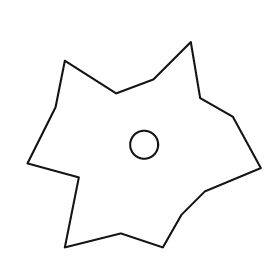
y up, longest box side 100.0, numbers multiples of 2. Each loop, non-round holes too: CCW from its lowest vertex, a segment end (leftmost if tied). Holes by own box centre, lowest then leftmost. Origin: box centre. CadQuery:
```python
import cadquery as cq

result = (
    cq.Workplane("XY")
    .moveTo(-34.0, -44.0)
    .lineTo(-10.0, -38.0)
    .lineTo(8.0, -44.0)
    .lineTo(16.0, -30.0)
    .lineTo(26.0, -20.0)
    .lineTo(50.0, -10.0)
    .lineTo(38.0, 12.0)
    .lineTo(24.0, 20.0)
    .lineTo(20.0, 44.0)
    .lineTo(4.0, 28.0)
    .lineTo(-12.0, 22.0)
    .lineTo(-34.0, 36.0)
    .lineTo(-38.0, 16.0)
    .lineTo(-50.0, -8.0)
    .lineTo(-28.0, -14.0)
    .close()
    .moveTo(0.0, 0.0)
    .circle(6.0)
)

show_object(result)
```